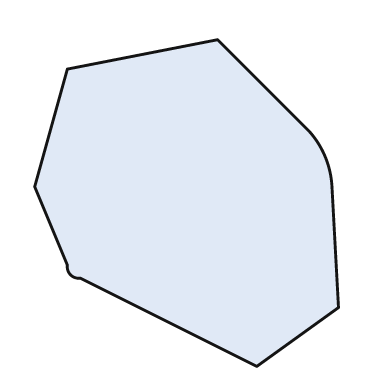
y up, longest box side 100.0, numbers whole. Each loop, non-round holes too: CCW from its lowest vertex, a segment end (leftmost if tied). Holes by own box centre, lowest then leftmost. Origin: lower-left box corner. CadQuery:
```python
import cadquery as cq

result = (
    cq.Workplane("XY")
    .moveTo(68.0, 0.0)
    .lineTo(93.0, 18.0)
    .lineTo(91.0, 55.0)
    .threePointArc((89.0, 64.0), (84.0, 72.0))
    .lineTo(56.0, 100.0)
    .lineTo(10.0, 91.0)
    .lineTo(0.0, 55.0)
    .lineTo(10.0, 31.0)
    .threePointArc((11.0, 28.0), (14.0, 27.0))
    .close()
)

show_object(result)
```